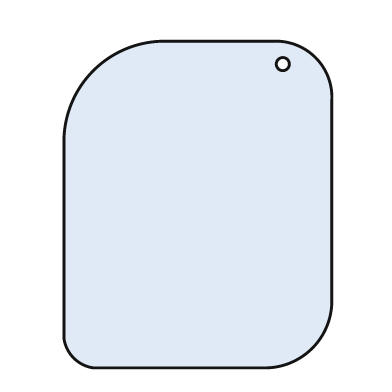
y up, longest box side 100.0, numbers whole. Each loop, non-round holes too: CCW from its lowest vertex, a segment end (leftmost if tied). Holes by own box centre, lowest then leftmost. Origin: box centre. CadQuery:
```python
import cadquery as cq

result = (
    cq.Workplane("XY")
    .moveTo(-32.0, -50.0)
    .lineTo(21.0, -50.0)
    .threePointArc((35.0, -44.0), (41.0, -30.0))
    .lineTo(41.0, 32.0)
    .threePointArc((36.0, 45.0), (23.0, 50.0))
    .lineTo(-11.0, 50.0)
    .threePointArc((-32.0, 41.0), (-41.0, 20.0))
    .lineTo(-41.0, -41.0)
    .threePointArc((-38.0, -47.0), (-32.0, -50.0))
    .close()
    .moveTo(26.0, 43.0)
    .circle(2.0)
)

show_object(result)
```